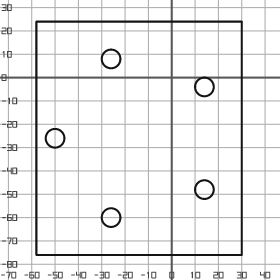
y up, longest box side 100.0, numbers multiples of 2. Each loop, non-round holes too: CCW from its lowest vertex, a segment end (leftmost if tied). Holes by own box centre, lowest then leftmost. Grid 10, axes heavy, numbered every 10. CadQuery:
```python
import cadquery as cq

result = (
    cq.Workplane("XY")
    .moveTo(-58.0, -76.0)
    .lineTo(30.0, -76.0)
    .lineTo(30.0, 24.0)
    .lineTo(-58.0, 24.0)
    .close()
    .moveTo(-26.0, -60.0)
    .circle(4.0)
    .moveTo(14.0, -48.0)
    .circle(4.0)
    .moveTo(-50.0, -26.0)
    .circle(4.0)
    .moveTo(14.0, -4.0)
    .circle(4.0)
    .moveTo(-26.0, 8.0)
    .circle(4.0)
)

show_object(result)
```